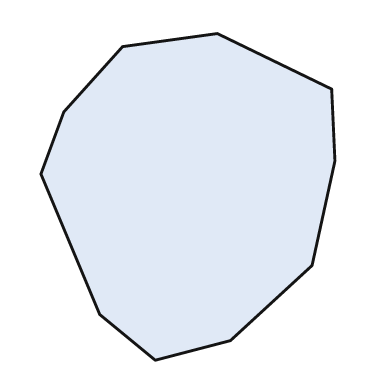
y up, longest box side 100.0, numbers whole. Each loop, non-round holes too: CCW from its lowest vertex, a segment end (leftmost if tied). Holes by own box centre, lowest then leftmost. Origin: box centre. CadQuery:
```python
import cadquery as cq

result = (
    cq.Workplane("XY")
    .moveTo(-10.0, -50.0)
    .lineTo(13.0, -44.0)
    .lineTo(38.0, -21.0)
    .lineTo(45.0, 11.0)
    .lineTo(44.0, 33.0)
    .lineTo(9.0, 50.0)
    .lineTo(-20.0, 46.0)
    .lineTo(-38.0, 26.0)
    .lineTo(-45.0, 7.0)
    .lineTo(-27.0, -36.0)
    .close()
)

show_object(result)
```